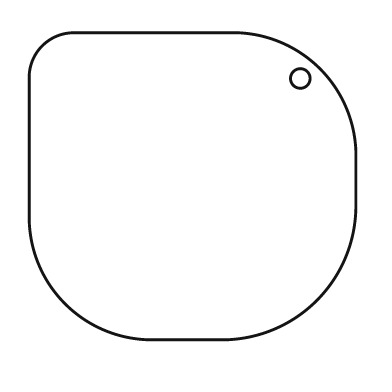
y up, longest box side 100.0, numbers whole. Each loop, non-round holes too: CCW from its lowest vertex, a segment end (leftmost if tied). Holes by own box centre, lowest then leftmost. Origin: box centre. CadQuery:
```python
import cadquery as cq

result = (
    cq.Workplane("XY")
    .moveTo(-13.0, -47.0)
    .lineTo(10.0, -47.0)
    .threePointArc((38.0, -35.0), (50.0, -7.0))
    .lineTo(50.0, 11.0)
    .threePointArc((39.0, 36.0), (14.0, 47.0))
    .lineTo(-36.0, 47.0)
    .threePointArc((-46.0, 43.0), (-50.0, 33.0))
    .lineTo(-50.0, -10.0)
    .threePointArc((-39.0, -36.0), (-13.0, -47.0))
    .close()
    .moveTo(33.0, 33.0)
    .circle(3.0)
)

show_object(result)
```